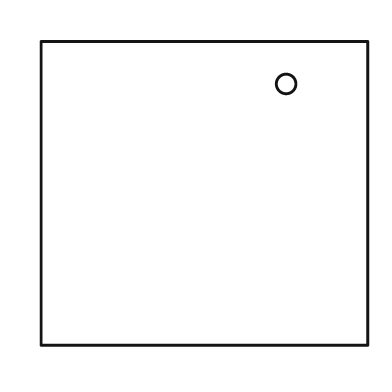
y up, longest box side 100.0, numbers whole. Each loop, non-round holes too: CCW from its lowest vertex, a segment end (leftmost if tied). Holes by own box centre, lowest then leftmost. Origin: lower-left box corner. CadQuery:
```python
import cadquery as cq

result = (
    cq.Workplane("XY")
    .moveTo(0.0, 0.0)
    .lineTo(100.0, 0.0)
    .lineTo(100.0, 93.0)
    .lineTo(0.0, 93.0)
    .close()
    .moveTo(75.0, 80.0)
    .circle(3.0)
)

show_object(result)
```